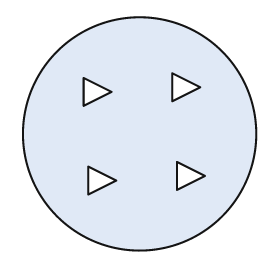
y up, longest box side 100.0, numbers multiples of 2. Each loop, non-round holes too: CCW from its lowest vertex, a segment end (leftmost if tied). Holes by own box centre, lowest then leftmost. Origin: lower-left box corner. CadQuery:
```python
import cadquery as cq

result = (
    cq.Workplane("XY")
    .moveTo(50.0, 50.0)
    .circle(50.0)
    .moveTo(28.0, 24.0)
    .lineTo(40.0, 30.0)
    .lineTo(28.0, 36.0)
    .close()
    .moveTo(66.0, 26.0)
    .lineTo(78.0, 32.0)
    .lineTo(66.0, 38.0)
    .close()
    .moveTo(26.0, 62.0)
    .lineTo(38.0, 68.0)
    .lineTo(26.0, 74.0)
    .close()
    .moveTo(64.0, 64.0)
    .lineTo(76.0, 70.0)
    .lineTo(64.0, 76.0)
    .close()
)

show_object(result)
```